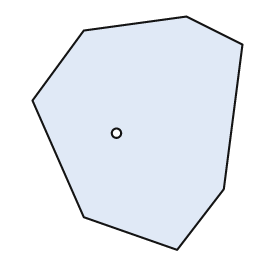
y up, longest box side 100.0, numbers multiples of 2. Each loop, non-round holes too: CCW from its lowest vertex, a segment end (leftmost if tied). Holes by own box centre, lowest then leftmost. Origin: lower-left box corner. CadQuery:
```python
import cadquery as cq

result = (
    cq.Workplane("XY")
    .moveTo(62.0, 0.0)
    .lineTo(82.0, 26.0)
    .lineTo(90.0, 88.0)
    .lineTo(66.0, 100.0)
    .lineTo(22.0, 94.0)
    .lineTo(0.0, 64.0)
    .lineTo(22.0, 14.0)
    .close()
    .moveTo(36.0, 50.0)
    .circle(2.0)
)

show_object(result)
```